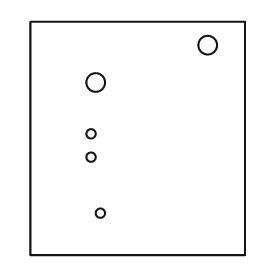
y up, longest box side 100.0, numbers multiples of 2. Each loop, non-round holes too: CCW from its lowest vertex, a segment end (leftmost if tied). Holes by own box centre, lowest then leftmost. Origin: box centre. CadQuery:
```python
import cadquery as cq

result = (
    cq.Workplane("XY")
    .moveTo(-46.0, -50.0)
    .lineTo(46.0, -50.0)
    .lineTo(46.0, 50.0)
    .lineTo(-46.0, 50.0)
    .close()
    .moveTo(-16.0, -32.0)
    .circle(2.0)
    .moveTo(-20.0, -8.0)
    .circle(2.0)
    .moveTo(-20.0, 2.0)
    .circle(2.0)
    .moveTo(-18.0, 24.0)
    .circle(4.0)
    .moveTo(30.0, 40.0)
    .circle(4.0)
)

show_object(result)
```